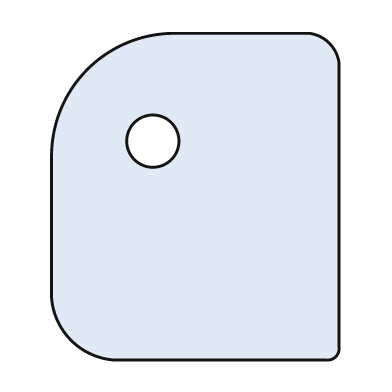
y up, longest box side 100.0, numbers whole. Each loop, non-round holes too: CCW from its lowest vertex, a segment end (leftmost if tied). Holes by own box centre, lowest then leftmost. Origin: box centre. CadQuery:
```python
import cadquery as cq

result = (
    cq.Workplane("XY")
    .moveTo(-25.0, -50.0)
    .lineTo(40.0, -50.0)
    .threePointArc((43.0, -49.0), (44.0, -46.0))
    .lineTo(44.0, 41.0)
    .threePointArc((41.0, 47.0), (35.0, 50.0))
    .lineTo(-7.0, 50.0)
    .threePointArc((-33.0, 39.0), (-44.0, 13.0))
    .lineTo(-44.0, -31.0)
    .threePointArc((-38.0, -44.0), (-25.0, -50.0))
    .close()
    .moveTo(-13.0, 17.0)
    .circle(8.0)
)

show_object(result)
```